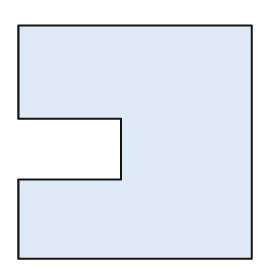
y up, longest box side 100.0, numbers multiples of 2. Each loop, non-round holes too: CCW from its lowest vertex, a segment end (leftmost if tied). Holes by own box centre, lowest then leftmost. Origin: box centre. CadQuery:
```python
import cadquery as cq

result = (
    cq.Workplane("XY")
    .moveTo(-50.0, -50.0)
    .lineTo(50.0, -50.0)
    .lineTo(50.0, 50.0)
    .lineTo(-50.0, 50.0)
    .lineTo(-50.0, 10.0)
    .lineTo(-6.0, 10.0)
    .lineTo(-6.0, -16.0)
    .lineTo(-50.0, -16.0)
    .close()
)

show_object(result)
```